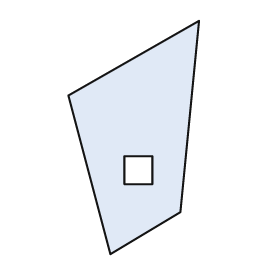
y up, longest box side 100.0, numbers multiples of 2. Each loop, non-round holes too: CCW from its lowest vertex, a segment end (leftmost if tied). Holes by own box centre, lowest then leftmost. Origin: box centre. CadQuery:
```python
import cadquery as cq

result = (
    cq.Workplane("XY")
    .moveTo(-10.0, -50.0)
    .lineTo(20.0, -32.0)
    .lineTo(28.0, 50.0)
    .lineTo(-28.0, 18.0)
    .close()
    .moveTo(-4.0, -20.0)
    .lineTo(8.0, -20.0)
    .lineTo(8.0, -8.0)
    .lineTo(-4.0, -8.0)
    .close()
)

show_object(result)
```